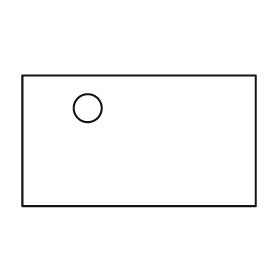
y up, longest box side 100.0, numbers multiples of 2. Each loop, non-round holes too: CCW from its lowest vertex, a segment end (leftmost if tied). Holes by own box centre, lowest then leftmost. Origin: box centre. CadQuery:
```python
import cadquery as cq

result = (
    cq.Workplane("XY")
    .moveTo(-50.0, -28.0)
    .lineTo(50.0, -28.0)
    .lineTo(50.0, 28.0)
    .lineTo(-50.0, 28.0)
    .close()
    .moveTo(-22.0, 14.0)
    .circle(6.0)
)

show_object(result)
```